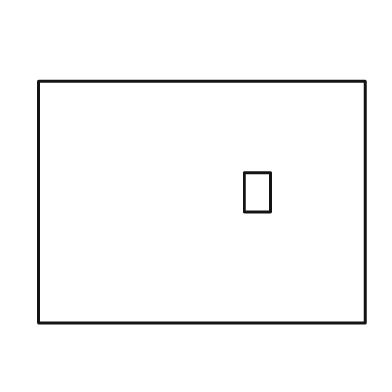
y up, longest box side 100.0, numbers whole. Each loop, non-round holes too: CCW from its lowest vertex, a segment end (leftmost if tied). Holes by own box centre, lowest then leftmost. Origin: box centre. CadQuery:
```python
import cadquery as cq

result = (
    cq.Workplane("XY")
    .moveTo(-50.0, -37.0)
    .lineTo(50.0, -37.0)
    .lineTo(50.0, 37.0)
    .lineTo(-50.0, 37.0)
    .close()
    .moveTo(13.0, -3.0)
    .lineTo(21.0, -3.0)
    .lineTo(21.0, 9.0)
    .lineTo(13.0, 9.0)
    .close()
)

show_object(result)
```